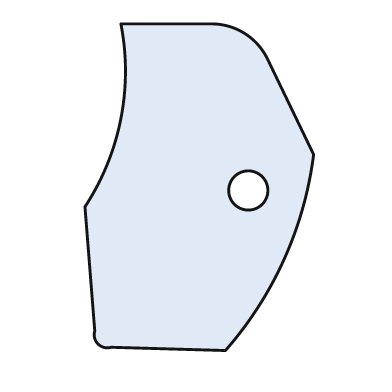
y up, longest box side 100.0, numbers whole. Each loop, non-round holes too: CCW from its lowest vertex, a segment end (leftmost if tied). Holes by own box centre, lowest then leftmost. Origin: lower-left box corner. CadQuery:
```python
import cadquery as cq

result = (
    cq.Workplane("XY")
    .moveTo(43.0, 0.0)
    .threePointArc((61.0, 28.0), (70.0, 60.0))
    .lineTo(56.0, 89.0)
    .threePointArc((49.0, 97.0), (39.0, 100.0))
    .lineTo(11.0, 100.0)
    .threePointArc((11.0, 71.0), (0.0, 44.0))
    .lineTo(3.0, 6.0)
    .threePointArc((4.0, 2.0), (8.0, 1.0))
    .close()
    .moveTo(50.0, 49.0)
    .circle(6.0)
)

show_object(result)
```